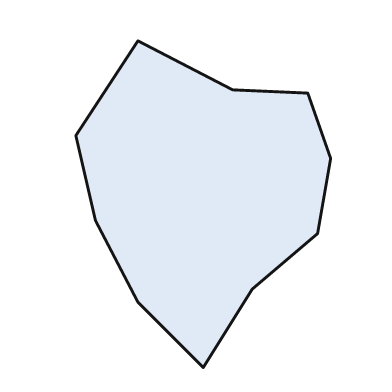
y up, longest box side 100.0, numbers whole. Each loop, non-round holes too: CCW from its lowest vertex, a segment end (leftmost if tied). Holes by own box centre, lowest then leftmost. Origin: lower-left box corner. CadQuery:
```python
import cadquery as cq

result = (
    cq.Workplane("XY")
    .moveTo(39.0, 0.0)
    .lineTo(54.0, 24.0)
    .lineTo(74.0, 41.0)
    .lineTo(78.0, 64.0)
    .lineTo(71.0, 84.0)
    .lineTo(48.0, 85.0)
    .lineTo(19.0, 100.0)
    .lineTo(0.0, 71.0)
    .lineTo(6.0, 45.0)
    .lineTo(19.0, 20.0)
    .close()
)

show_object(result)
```